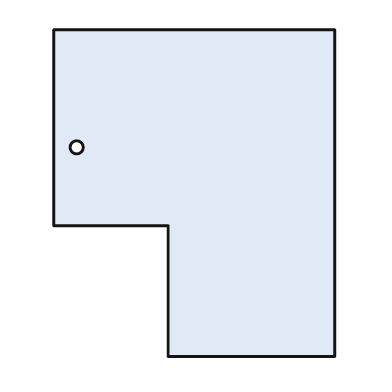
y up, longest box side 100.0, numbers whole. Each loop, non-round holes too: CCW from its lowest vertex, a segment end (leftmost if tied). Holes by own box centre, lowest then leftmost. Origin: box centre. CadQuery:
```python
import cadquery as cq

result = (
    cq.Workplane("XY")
    .moveTo(-8.0, -50.0)
    .lineTo(43.0, -50.0)
    .lineTo(43.0, 50.0)
    .lineTo(-43.0, 50.0)
    .lineTo(-43.0, -10.0)
    .lineTo(-8.0, -10.0)
    .close()
    .moveTo(-36.0, 14.0)
    .circle(2.0)
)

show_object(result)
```